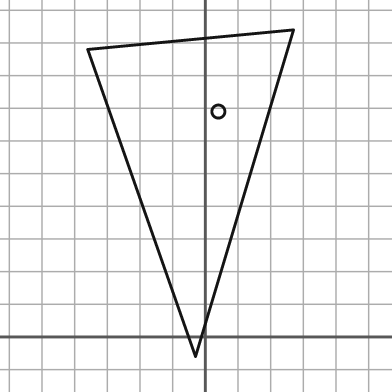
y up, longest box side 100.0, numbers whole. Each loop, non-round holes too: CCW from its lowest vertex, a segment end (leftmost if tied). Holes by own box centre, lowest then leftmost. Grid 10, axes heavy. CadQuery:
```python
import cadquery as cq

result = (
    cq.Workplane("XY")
    .moveTo(-3.0, -6.0)
    .lineTo(27.0, 94.0)
    .lineTo(-36.0, 88.0)
    .close()
    .moveTo(4.0, 69.0)
    .circle(2.0)
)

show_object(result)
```